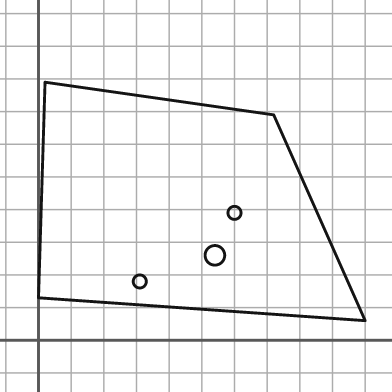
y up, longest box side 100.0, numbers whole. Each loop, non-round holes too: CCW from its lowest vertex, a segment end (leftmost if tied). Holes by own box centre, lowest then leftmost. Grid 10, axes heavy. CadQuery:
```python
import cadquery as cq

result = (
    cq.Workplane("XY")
    .moveTo(100.0, 6.0)
    .lineTo(72.0, 69.0)
    .lineTo(2.0, 79.0)
    .lineTo(0.0, 13.0)
    .close()
    .moveTo(31.0, 18.0)
    .circle(2.0)
    .moveTo(54.0, 26.0)
    .circle(3.0)
    .moveTo(60.0, 39.0)
    .circle(2.0)
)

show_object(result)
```